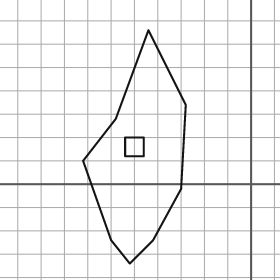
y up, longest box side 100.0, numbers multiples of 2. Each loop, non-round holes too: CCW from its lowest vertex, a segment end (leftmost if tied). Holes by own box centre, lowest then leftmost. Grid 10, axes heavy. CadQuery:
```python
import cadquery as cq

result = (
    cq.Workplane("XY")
    .moveTo(-52.0, -34.0)
    .lineTo(-42.0, -24.0)
    .lineTo(-30.0, -2.0)
    .lineTo(-28.0, 34.0)
    .lineTo(-44.0, 66.0)
    .lineTo(-58.0, 28.0)
    .lineTo(-72.0, 10.0)
    .lineTo(-60.0, -24.0)
    .close()
    .moveTo(-54.0, 12.0)
    .lineTo(-46.0, 12.0)
    .lineTo(-46.0, 20.0)
    .lineTo(-54.0, 20.0)
    .close()
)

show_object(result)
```